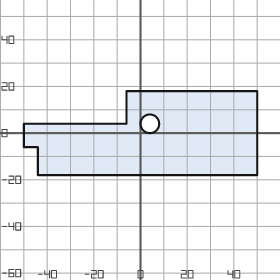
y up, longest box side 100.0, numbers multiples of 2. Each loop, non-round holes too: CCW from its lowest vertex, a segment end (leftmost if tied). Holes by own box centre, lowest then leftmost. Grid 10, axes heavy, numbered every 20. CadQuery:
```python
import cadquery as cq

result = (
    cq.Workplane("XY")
    .moveTo(-44.0, -18.0)
    .lineTo(50.0, -18.0)
    .lineTo(50.0, 18.0)
    .lineTo(-6.0, 18.0)
    .lineTo(-6.0, 4.0)
    .lineTo(-50.0, 4.0)
    .lineTo(-50.0, -6.0)
    .lineTo(-44.0, -6.0)
    .close()
    .moveTo(4.0, 4.0)
    .circle(4.0)
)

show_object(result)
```